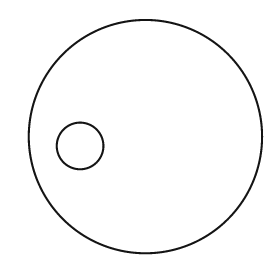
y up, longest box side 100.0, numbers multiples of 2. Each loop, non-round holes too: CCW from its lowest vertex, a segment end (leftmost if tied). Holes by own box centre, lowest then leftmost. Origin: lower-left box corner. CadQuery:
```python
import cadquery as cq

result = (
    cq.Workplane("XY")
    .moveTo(50.0, 50.0)
    .circle(50.0)
    .moveTo(22.0, 46.0)
    .circle(10.0)
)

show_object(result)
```